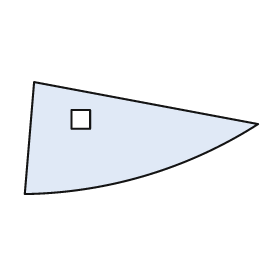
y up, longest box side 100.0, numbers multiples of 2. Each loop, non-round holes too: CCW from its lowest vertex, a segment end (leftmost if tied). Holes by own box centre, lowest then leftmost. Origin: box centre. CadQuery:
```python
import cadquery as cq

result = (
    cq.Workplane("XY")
    .moveTo(-50.0, -24.0)
    .threePointArc((2.0, -16.0), (50.0, 6.0))
    .lineTo(-46.0, 24.0)
    .close()
    .moveTo(-30.0, 4.0)
    .lineTo(-22.0, 4.0)
    .lineTo(-22.0, 12.0)
    .lineTo(-30.0, 12.0)
    .close()
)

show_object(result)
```